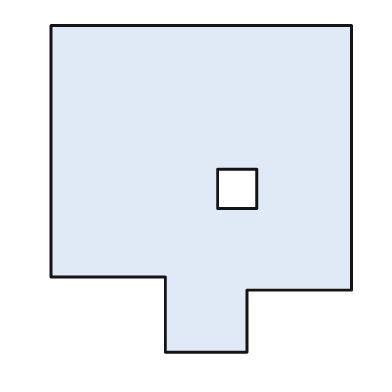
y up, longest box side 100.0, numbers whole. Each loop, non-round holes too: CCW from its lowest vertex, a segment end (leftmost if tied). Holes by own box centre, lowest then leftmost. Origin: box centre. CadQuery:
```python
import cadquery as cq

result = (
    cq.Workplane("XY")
    .moveTo(-11.0, -50.0)
    .lineTo(14.0, -50.0)
    .lineTo(14.0, -31.0)
    .lineTo(46.0, -31.0)
    .lineTo(46.0, 50.0)
    .lineTo(-46.0, 50.0)
    .lineTo(-46.0, -27.0)
    .lineTo(-11.0, -27.0)
    .close()
    .moveTo(5.0, -6.0)
    .lineTo(17.0, -6.0)
    .lineTo(17.0, 6.0)
    .lineTo(5.0, 6.0)
    .close()
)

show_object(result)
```